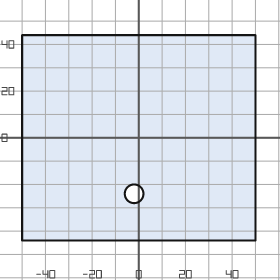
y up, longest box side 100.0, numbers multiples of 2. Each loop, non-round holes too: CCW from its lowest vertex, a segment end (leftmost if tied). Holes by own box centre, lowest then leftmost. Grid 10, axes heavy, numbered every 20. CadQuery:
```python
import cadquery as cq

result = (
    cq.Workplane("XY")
    .moveTo(-50.0, -44.0)
    .lineTo(50.0, -44.0)
    .lineTo(50.0, 44.0)
    .lineTo(-50.0, 44.0)
    .close()
    .moveTo(-2.0, -24.0)
    .circle(4.0)
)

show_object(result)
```